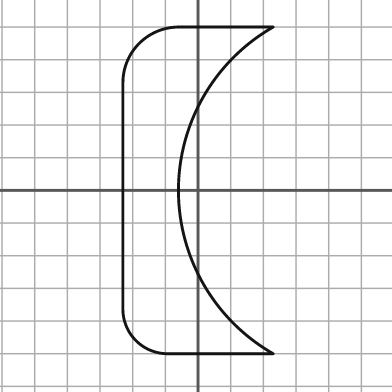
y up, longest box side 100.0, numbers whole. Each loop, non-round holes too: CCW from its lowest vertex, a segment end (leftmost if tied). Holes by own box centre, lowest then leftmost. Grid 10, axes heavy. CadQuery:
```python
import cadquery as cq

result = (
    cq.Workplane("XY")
    .moveTo(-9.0, -50.0)
    .lineTo(23.0, -50.0)
    .threePointArc((-6.0, 0.0), (23.0, 50.0))
    .lineTo(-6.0, 50.0)
    .threePointArc((-18.0, 45.0), (-23.0, 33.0))
    .lineTo(-23.0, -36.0)
    .threePointArc((-19.0, -46.0), (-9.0, -50.0))
    .close()
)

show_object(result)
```